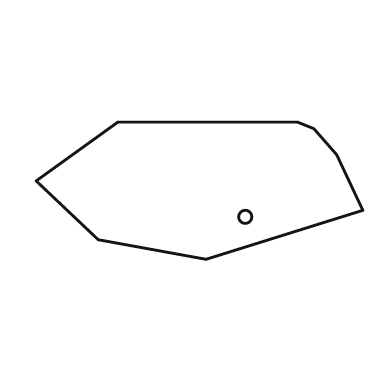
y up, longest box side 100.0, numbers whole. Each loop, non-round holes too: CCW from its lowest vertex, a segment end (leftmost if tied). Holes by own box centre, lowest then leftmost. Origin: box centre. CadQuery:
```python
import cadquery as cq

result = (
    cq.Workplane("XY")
    .moveTo(2.0, -21.0)
    .lineTo(50.0, -6.0)
    .lineTo(42.0, 11.0)
    .lineTo(35.0, 19.0)
    .lineTo(30.0, 21.0)
    .lineTo(-25.0, 21.0)
    .lineTo(-50.0, 3.0)
    .lineTo(-31.0, -15.0)
    .close()
    .moveTo(14.0, -8.0)
    .circle(2.0)
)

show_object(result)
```